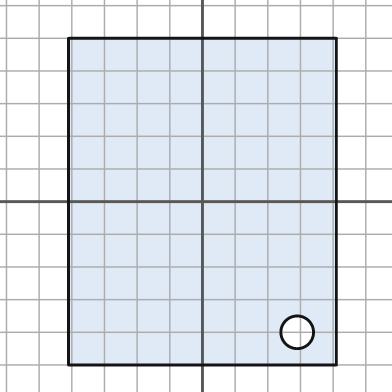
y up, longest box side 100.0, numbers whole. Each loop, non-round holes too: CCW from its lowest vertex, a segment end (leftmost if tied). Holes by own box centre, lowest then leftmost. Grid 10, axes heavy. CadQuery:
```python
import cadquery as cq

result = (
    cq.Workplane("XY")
    .moveTo(-41.0, -50.0)
    .lineTo(41.0, -50.0)
    .lineTo(41.0, 50.0)
    .lineTo(-41.0, 50.0)
    .close()
    .moveTo(29.0, -40.0)
    .circle(5.0)
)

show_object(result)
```